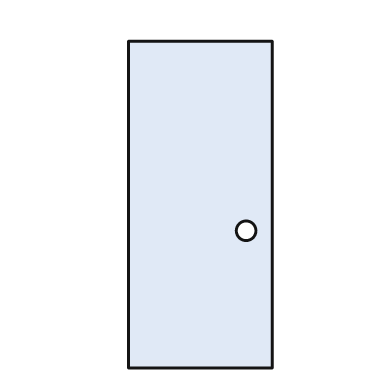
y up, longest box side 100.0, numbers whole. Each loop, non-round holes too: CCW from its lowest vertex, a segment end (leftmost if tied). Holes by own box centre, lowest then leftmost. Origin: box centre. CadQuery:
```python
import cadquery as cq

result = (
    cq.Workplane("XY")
    .moveTo(-22.0, -50.0)
    .lineTo(22.0, -50.0)
    .lineTo(22.0, 50.0)
    .lineTo(-22.0, 50.0)
    .close()
    .moveTo(14.0, -8.0)
    .circle(3.0)
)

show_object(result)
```